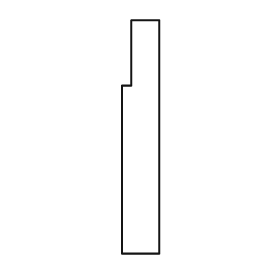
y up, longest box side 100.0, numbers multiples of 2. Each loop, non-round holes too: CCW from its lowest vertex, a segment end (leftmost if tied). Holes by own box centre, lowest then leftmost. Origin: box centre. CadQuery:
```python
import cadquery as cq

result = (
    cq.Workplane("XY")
    .moveTo(-8.0, -50.0)
    .lineTo(8.0, -50.0)
    .lineTo(8.0, 50.0)
    .lineTo(-4.0, 50.0)
    .lineTo(-4.0, 22.0)
    .lineTo(-8.0, 22.0)
    .close()
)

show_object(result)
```